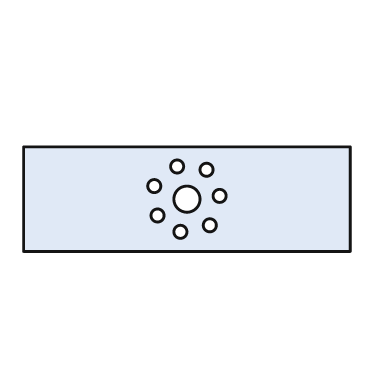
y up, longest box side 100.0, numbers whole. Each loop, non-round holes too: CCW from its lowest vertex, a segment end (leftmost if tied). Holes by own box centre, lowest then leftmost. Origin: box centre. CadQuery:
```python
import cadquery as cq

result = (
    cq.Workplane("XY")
    .moveTo(-50.0, -16.0)
    .lineTo(50.0, -16.0)
    .lineTo(50.0, 16.0)
    .lineTo(-50.0, 16.0)
    .close()
    .moveTo(-2.0, -10.0)
    .circle(2.0)
    .moveTo(7.0, -8.0)
    .circle(2.0)
    .moveTo(-9.0, -5.0)
    .circle(2.0)
    .moveTo(0.0, 0.0)
    .circle(4.0)
    .moveTo(10.0, 1.0)
    .circle(2.0)
    .moveTo(-10.0, 4.0)
    .circle(2.0)
    .moveTo(6.0, 9.0)
    .circle(2.0)
    .moveTo(-3.0, 10.0)
    .circle(2.0)
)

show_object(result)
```